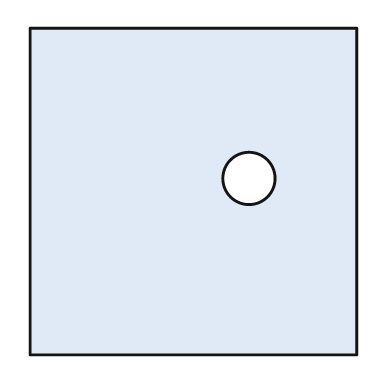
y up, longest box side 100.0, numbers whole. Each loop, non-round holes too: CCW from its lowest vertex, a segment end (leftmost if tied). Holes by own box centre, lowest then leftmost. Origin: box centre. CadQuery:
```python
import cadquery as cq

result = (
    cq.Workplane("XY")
    .moveTo(-50.0, -50.0)
    .lineTo(50.0, -50.0)
    .lineTo(50.0, 50.0)
    .lineTo(-50.0, 50.0)
    .close()
    .moveTo(17.0, 4.0)
    .circle(8.0)
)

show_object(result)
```